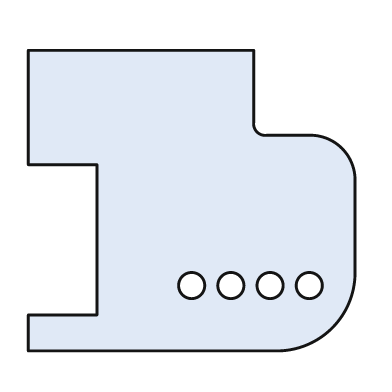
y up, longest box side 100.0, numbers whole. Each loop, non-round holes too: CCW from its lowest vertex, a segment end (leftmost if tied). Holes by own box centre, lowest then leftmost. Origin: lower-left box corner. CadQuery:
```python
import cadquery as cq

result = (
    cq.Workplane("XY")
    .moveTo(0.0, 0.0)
    .lineTo(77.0, 0.0)
    .threePointArc((93.0, 7.0), (100.0, 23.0))
    .lineTo(100.0, 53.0)
    .threePointArc((96.0, 62.0), (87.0, 66.0))
    .lineTo(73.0, 66.0)
    .threePointArc((70.0, 67.0), (69.0, 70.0))
    .lineTo(69.0, 92.0)
    .lineTo(0.0, 92.0)
    .lineTo(0.0, 57.0)
    .lineTo(21.0, 57.0)
    .lineTo(21.0, 11.0)
    .lineTo(0.0, 11.0)
    .close()
    .moveTo(50.0, 20.0)
    .circle(4.0)
    .moveTo(62.0, 20.0)
    .circle(4.0)
    .moveTo(74.0, 20.0)
    .circle(4.0)
    .moveTo(86.0, 20.0)
    .circle(4.0)
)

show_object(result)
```